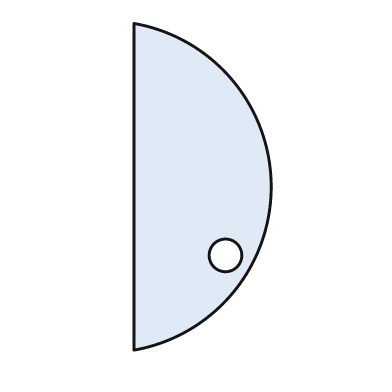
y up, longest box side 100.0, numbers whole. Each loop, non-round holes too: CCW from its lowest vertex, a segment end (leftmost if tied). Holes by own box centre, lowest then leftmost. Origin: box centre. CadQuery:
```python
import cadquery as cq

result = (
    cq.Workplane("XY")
    .moveTo(-21.0, -50.0)
    .threePointArc((21.0, 0.0), (-21.0, 50.0))
    .close()
    .moveTo(7.0, -21.0)
    .circle(5.0)
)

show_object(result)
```